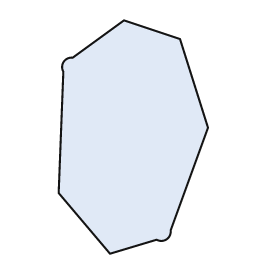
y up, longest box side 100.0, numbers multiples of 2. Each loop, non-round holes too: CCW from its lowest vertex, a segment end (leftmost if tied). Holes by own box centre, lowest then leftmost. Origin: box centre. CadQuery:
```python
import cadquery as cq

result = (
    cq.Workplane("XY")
    .moveTo(-10.0, -50.0)
    .lineTo(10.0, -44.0)
    .threePointArc((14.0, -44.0), (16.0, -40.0))
    .lineTo(32.0, 4.0)
    .lineTo(20.0, 42.0)
    .lineTo(-4.0, 50.0)
    .lineTo(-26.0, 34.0)
    .threePointArc((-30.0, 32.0), (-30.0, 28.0))
    .lineTo(-32.0, -24.0)
    .close()
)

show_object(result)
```